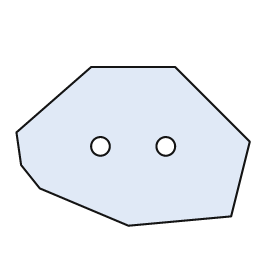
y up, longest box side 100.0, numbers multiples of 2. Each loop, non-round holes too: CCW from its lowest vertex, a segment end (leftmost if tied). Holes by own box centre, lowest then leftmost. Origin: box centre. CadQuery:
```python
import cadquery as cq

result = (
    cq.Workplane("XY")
    .moveTo(-2.0, -34.0)
    .lineTo(42.0, -30.0)
    .lineTo(50.0, 2.0)
    .lineTo(18.0, 34.0)
    .lineTo(-18.0, 34.0)
    .lineTo(-50.0, 6.0)
    .lineTo(-48.0, -8.0)
    .lineTo(-40.0, -18.0)
    .close()
    .moveTo(-14.0, 0.0)
    .circle(4.0)
    .moveTo(14.0, 0.0)
    .circle(4.0)
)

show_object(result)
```